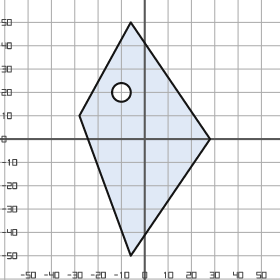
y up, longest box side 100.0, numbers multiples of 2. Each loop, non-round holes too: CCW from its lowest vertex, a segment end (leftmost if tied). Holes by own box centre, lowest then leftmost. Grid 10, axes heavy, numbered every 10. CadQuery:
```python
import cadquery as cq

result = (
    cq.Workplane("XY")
    .moveTo(-6.0, -50.0)
    .lineTo(28.0, 0.0)
    .lineTo(-6.0, 50.0)
    .lineTo(-28.0, 10.0)
    .close()
    .moveTo(-10.0, 20.0)
    .circle(4.0)
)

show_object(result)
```